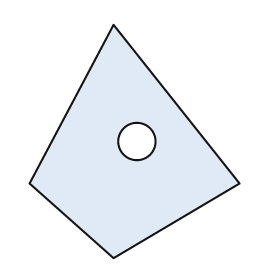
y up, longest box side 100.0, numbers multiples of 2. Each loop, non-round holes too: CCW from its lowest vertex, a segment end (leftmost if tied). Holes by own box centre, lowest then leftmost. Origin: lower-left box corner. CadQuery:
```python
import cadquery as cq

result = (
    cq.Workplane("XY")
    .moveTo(36.0, 0.0)
    .lineTo(90.0, 32.0)
    .lineTo(36.0, 100.0)
    .lineTo(0.0, 32.0)
    .close()
    .moveTo(46.0, 50.0)
    .circle(8.0)
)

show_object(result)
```